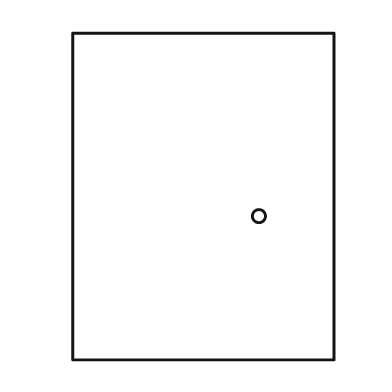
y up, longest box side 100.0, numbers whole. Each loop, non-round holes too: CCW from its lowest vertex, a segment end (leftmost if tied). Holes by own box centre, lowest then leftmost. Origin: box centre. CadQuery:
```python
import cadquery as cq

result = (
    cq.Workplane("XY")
    .moveTo(-40.0, -50.0)
    .lineTo(40.0, -50.0)
    .lineTo(40.0, 50.0)
    .lineTo(-40.0, 50.0)
    .close()
    .moveTo(17.0, -6.0)
    .circle(2.0)
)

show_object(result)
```